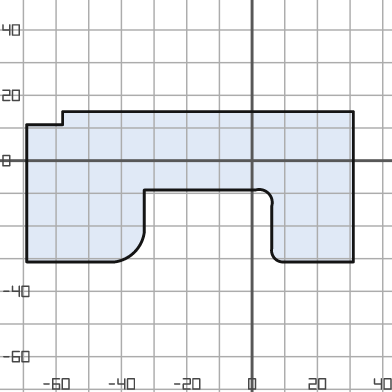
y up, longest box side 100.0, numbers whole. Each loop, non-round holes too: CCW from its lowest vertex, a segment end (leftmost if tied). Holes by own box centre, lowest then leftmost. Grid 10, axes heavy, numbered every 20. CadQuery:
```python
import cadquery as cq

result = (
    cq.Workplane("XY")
    .moveTo(-69.0, -31.0)
    .lineTo(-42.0, -31.0)
    .threePointArc((-36.0, -28.0), (-33.0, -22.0))
    .lineTo(-33.0, -9.0)
    .lineTo(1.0, -9.0)
    .threePointArc((5.0, -10.0), (6.0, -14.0))
    .lineTo(6.0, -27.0)
    .threePointArc((7.0, -30.0), (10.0, -31.0))
    .lineTo(31.0, -31.0)
    .lineTo(31.0, 15.0)
    .lineTo(-58.0, 15.0)
    .lineTo(-58.0, 11.0)
    .lineTo(-69.0, 11.0)
    .close()
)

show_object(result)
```